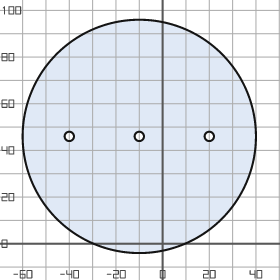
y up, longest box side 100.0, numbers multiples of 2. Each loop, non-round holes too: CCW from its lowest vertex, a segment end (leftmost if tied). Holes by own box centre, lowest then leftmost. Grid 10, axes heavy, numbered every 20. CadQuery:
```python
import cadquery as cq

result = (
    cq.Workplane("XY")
    .moveTo(-10.0, 46.0)
    .circle(50.0)
    .moveTo(-40.0, 46.0)
    .circle(2.0)
    .moveTo(-10.0, 46.0)
    .circle(2.0)
    .moveTo(20.0, 46.0)
    .circle(2.0)
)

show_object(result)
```